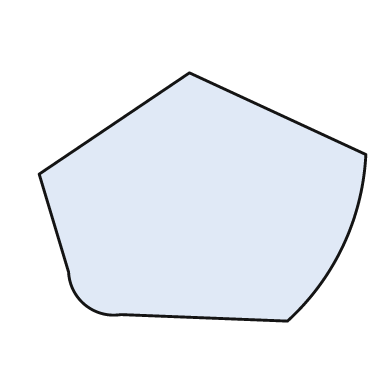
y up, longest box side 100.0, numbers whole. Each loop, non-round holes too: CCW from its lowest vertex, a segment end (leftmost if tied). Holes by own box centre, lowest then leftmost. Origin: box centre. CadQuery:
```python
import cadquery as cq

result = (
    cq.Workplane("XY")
    .moveTo(26.0, -38.0)
    .threePointArc((43.0, -15.0), (50.0, 13.0))
    .lineTo(-4.0, 38.0)
    .lineTo(-50.0, 7.0)
    .lineTo(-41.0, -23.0)
    .threePointArc((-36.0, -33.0), (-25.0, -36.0))
    .close()
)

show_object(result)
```